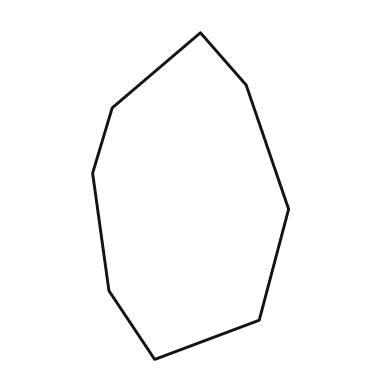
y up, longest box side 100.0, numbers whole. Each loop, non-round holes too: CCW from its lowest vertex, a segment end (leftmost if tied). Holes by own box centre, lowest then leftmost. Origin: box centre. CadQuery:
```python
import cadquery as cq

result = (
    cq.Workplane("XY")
    .moveTo(-11.0, -50.0)
    .lineTo(21.0, -38.0)
    .lineTo(30.0, -4.0)
    .lineTo(17.0, 34.0)
    .lineTo(3.0, 50.0)
    .lineTo(-24.0, 27.0)
    .lineTo(-30.0, 7.0)
    .lineTo(-25.0, -29.0)
    .close()
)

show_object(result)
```